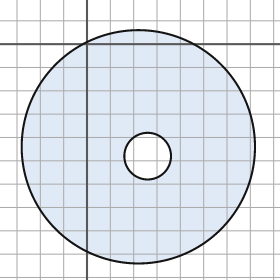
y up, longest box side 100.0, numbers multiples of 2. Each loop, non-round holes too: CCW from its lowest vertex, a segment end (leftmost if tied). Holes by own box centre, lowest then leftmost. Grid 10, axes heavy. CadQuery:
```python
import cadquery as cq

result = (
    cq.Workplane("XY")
    .moveTo(22.0, -44.0)
    .circle(50.0)
    .moveTo(26.0, -48.0)
    .circle(10.0)
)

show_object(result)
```